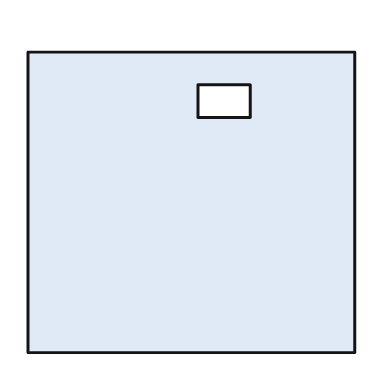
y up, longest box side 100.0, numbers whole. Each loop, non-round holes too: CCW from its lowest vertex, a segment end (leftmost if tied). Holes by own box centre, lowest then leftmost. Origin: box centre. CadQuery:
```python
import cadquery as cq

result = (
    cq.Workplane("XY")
    .moveTo(-50.0, -46.0)
    .lineTo(50.0, -46.0)
    .lineTo(50.0, 46.0)
    .lineTo(-50.0, 46.0)
    .close()
    .moveTo(2.0, 26.0)
    .lineTo(18.0, 26.0)
    .lineTo(18.0, 36.0)
    .lineTo(2.0, 36.0)
    .close()
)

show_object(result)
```